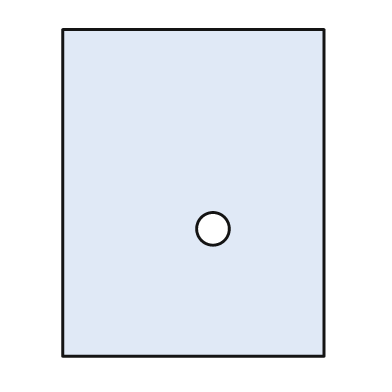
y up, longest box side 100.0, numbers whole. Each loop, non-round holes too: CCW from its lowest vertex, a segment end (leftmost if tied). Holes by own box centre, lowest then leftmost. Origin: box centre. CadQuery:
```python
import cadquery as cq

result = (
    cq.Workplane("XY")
    .moveTo(-40.0, -50.0)
    .lineTo(40.0, -50.0)
    .lineTo(40.0, 50.0)
    .lineTo(-40.0, 50.0)
    .close()
    .moveTo(6.0, -11.0)
    .circle(5.0)
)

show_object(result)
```